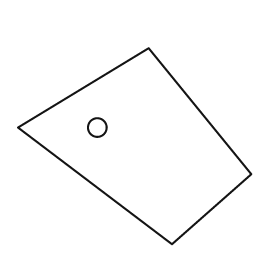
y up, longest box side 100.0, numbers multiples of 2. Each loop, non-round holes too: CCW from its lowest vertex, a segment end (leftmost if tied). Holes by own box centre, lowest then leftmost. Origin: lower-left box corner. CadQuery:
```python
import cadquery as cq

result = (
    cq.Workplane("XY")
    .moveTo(66.0, 0.0)
    .lineTo(100.0, 30.0)
    .lineTo(56.0, 84.0)
    .lineTo(0.0, 50.0)
    .close()
    .moveTo(34.0, 50.0)
    .circle(4.0)
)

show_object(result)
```